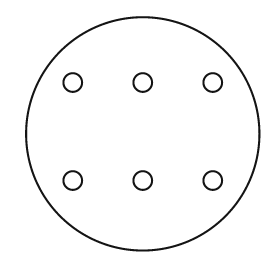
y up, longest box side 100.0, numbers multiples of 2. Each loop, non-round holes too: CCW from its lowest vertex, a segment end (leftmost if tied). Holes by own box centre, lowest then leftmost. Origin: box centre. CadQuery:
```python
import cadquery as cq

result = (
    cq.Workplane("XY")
    .moveTo(0.0, 0.0)
    .circle(50.0)
    .moveTo(-30.0, -20.0)
    .circle(4.0)
    .moveTo(0.0, -20.0)
    .circle(4.0)
    .moveTo(30.0, -20.0)
    .circle(4.0)
    .moveTo(-30.0, 22.0)
    .circle(4.0)
    .moveTo(0.0, 22.0)
    .circle(4.0)
    .moveTo(30.0, 22.0)
    .circle(4.0)
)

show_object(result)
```